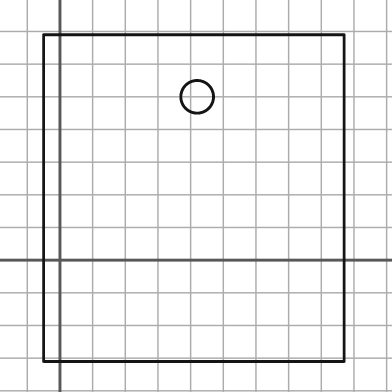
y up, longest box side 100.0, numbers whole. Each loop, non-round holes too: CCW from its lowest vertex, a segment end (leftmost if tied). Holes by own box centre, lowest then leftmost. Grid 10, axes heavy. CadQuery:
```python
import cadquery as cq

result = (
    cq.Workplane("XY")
    .moveTo(-5.0, -31.0)
    .lineTo(87.0, -31.0)
    .lineTo(87.0, 69.0)
    .lineTo(-5.0, 69.0)
    .close()
    .moveTo(42.0, 50.0)
    .circle(5.0)
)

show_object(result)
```